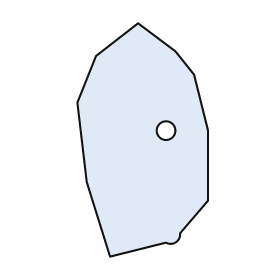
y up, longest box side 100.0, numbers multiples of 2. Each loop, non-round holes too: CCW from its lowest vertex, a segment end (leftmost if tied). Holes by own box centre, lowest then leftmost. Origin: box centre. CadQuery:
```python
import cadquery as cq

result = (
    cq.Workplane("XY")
    .moveTo(-14.0, -50.0)
    .lineTo(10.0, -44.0)
    .threePointArc((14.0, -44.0), (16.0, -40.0))
    .lineTo(28.0, -26.0)
    .lineTo(28.0, 4.0)
    .lineTo(22.0, 28.0)
    .lineTo(14.0, 38.0)
    .lineTo(-2.0, 50.0)
    .lineTo(-20.0, 36.0)
    .lineTo(-28.0, 16.0)
    .lineTo(-24.0, -18.0)
    .close()
    .moveTo(10.0, 4.0)
    .circle(4.0)
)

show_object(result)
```